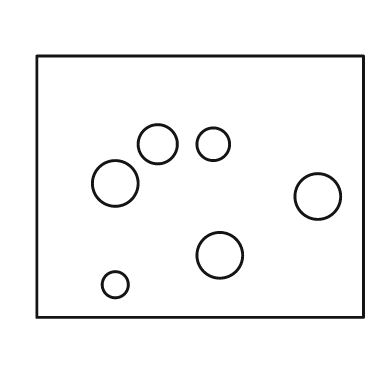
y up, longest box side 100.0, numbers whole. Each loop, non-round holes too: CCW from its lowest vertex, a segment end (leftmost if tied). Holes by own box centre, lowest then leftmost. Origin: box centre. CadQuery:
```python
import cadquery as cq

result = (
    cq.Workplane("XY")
    .moveTo(-50.0, -40.0)
    .lineTo(50.0, -40.0)
    .lineTo(50.0, 40.0)
    .lineTo(-50.0, 40.0)
    .close()
    .moveTo(-26.0, -30.0)
    .circle(4.0)
    .moveTo(6.0, -21.0)
    .circle(7.0)
    .moveTo(36.0, -3.0)
    .circle(7.0)
    .moveTo(-26.0, 1.0)
    .circle(7.0)
    .moveTo(-13.0, 13.0)
    .circle(6.0)
    .moveTo(4.0, 13.0)
    .circle(5.0)
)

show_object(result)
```